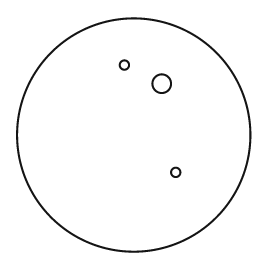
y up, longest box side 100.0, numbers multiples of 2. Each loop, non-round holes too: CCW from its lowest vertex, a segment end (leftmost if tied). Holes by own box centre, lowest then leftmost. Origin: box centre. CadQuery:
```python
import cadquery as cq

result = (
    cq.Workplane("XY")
    .moveTo(0.0, 0.0)
    .circle(50.0)
    .moveTo(18.0, -16.0)
    .circle(2.0)
    .moveTo(12.0, 22.0)
    .circle(4.0)
    .moveTo(-4.0, 30.0)
    .circle(2.0)
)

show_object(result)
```